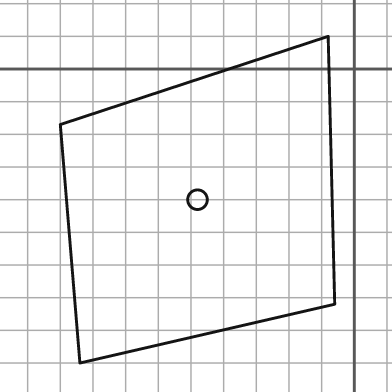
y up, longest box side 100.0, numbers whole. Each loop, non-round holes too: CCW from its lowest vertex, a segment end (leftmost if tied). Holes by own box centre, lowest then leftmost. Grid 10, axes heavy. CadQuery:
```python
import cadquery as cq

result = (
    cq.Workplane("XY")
    .moveTo(-84.0, -90.0)
    .lineTo(-6.0, -72.0)
    .lineTo(-8.0, 10.0)
    .lineTo(-90.0, -17.0)
    .close()
    .moveTo(-48.0, -40.0)
    .circle(3.0)
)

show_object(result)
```